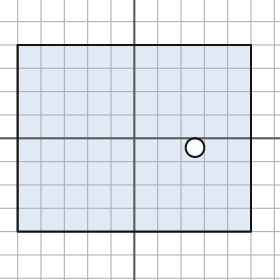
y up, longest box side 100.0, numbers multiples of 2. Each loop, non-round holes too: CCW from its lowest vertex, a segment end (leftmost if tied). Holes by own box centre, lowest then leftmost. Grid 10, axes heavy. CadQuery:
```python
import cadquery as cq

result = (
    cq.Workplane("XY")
    .moveTo(-50.0, -40.0)
    .lineTo(50.0, -40.0)
    .lineTo(50.0, 40.0)
    .lineTo(-50.0, 40.0)
    .close()
    .moveTo(26.0, -4.0)
    .circle(4.0)
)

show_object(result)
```